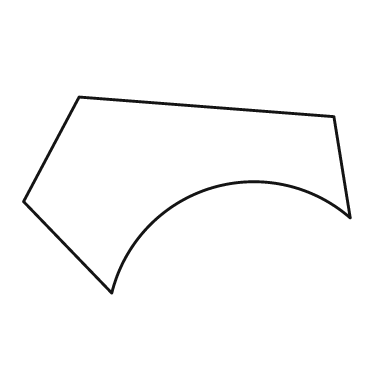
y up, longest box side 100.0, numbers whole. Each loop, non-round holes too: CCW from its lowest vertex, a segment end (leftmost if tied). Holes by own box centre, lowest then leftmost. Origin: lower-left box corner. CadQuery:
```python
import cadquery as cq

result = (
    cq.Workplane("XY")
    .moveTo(27.0, 0.0)
    .threePointArc((57.0, 32.0), (100.0, 23.0))
    .lineTo(95.0, 54.0)
    .lineTo(17.0, 60.0)
    .lineTo(0.0, 28.0)
    .close()
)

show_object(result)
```